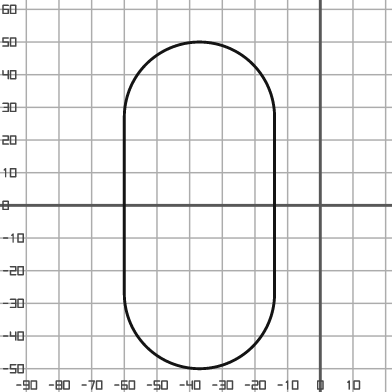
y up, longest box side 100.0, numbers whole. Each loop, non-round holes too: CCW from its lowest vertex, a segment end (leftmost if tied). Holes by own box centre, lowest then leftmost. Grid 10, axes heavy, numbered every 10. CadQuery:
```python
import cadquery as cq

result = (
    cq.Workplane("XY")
    .moveTo(-60.0, -27.0)
    .threePointArc((-37.0, -50.0), (-14.0, -27.0))
    .lineTo(-14.0, 27.0)
    .threePointArc((-37.0, 50.0), (-60.0, 27.0))
    .close()
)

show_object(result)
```